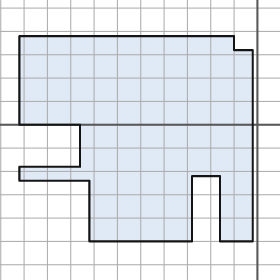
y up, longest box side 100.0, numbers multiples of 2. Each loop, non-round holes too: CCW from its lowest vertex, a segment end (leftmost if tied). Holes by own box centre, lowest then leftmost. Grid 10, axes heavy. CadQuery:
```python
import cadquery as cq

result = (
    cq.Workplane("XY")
    .moveTo(-72.0, -50.0)
    .lineTo(-28.0, -50.0)
    .lineTo(-28.0, -22.0)
    .lineTo(-16.0, -22.0)
    .lineTo(-16.0, -50.0)
    .lineTo(-2.0, -50.0)
    .lineTo(-2.0, 32.0)
    .lineTo(-10.0, 32.0)
    .lineTo(-10.0, 38.0)
    .lineTo(-102.0, 38.0)
    .lineTo(-102.0, 0.0)
    .lineTo(-76.0, 0.0)
    .lineTo(-76.0, -18.0)
    .lineTo(-102.0, -18.0)
    .lineTo(-102.0, -24.0)
    .lineTo(-72.0, -24.0)
    .close()
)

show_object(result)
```